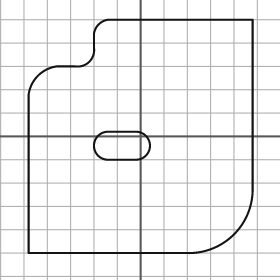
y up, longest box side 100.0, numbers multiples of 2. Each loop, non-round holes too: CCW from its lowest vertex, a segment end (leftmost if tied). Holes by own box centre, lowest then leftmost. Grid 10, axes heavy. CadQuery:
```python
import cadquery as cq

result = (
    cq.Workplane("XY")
    .moveTo(-48.0, -50.0)
    .lineTo(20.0, -50.0)
    .threePointArc((40.0, -42.0), (48.0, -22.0))
    .lineTo(48.0, 50.0)
    .lineTo(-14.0, 50.0)
    .threePointArc((-18.0, 48.0), (-20.0, 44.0))
    .lineTo(-20.0, 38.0)
    .threePointArc((-22.0, 32.0), (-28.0, 30.0))
    .lineTo(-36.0, 30.0)
    .threePointArc((-44.0, 26.0), (-48.0, 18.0))
    .close()
    .moveTo(-14.0, -10.0)
    .lineTo(-2.0, -10.0)
    .threePointArc((4.0, -4.0), (-2.0, 2.0))
    .lineTo(-14.0, 2.0)
    .threePointArc((-20.0, -4.0), (-14.0, -10.0))
    .close()
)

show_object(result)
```